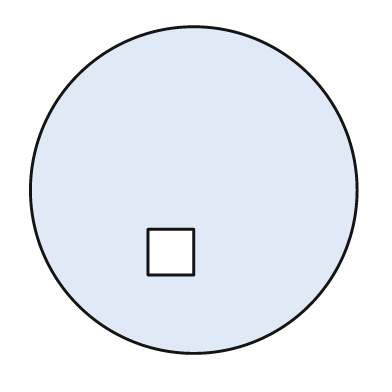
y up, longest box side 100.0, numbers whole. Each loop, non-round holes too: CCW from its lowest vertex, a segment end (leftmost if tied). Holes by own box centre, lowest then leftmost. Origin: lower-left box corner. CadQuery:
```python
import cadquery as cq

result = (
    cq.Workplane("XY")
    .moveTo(50.0, 50.0)
    .circle(50.0)
    .moveTo(36.0, 24.0)
    .lineTo(50.0, 24.0)
    .lineTo(50.0, 38.0)
    .lineTo(36.0, 38.0)
    .close()
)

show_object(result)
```